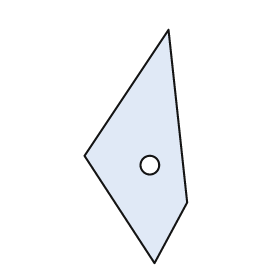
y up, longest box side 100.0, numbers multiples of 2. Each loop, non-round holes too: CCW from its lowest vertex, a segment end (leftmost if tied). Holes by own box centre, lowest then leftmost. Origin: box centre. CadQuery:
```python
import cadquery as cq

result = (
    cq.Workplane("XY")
    .moveTo(8.0, -50.0)
    .lineTo(22.0, -24.0)
    .lineTo(14.0, 50.0)
    .lineTo(-22.0, -4.0)
    .close()
    .moveTo(6.0, -8.0)
    .circle(4.0)
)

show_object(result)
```